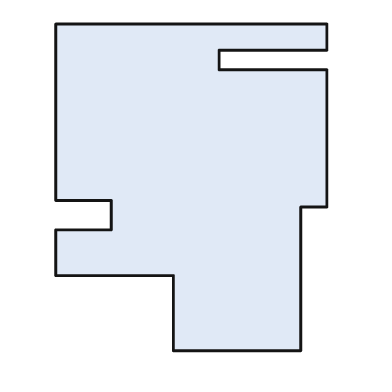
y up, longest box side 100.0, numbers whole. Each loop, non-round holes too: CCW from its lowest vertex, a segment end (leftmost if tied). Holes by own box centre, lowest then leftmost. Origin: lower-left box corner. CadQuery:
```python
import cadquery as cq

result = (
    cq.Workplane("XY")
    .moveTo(36.0, 0.0)
    .lineTo(75.0, 0.0)
    .lineTo(75.0, 44.0)
    .lineTo(83.0, 44.0)
    .lineTo(83.0, 86.0)
    .lineTo(50.0, 86.0)
    .lineTo(50.0, 92.0)
    .lineTo(83.0, 92.0)
    .lineTo(83.0, 100.0)
    .lineTo(0.0, 100.0)
    .lineTo(0.0, 46.0)
    .lineTo(17.0, 46.0)
    .lineTo(17.0, 37.0)
    .lineTo(0.0, 37.0)
    .lineTo(0.0, 23.0)
    .lineTo(36.0, 23.0)
    .close()
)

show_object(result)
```